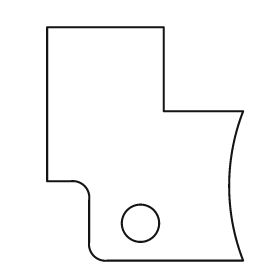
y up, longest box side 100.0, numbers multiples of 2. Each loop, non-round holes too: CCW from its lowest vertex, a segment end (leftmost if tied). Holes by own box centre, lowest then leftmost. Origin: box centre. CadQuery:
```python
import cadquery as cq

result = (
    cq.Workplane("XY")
    .moveTo(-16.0, -50.0)
    .lineTo(42.0, -50.0)
    .threePointArc((36.0, -18.0), (42.0, 14.0))
    .lineTo(8.0, 14.0)
    .lineTo(8.0, 50.0)
    .lineTo(-42.0, 50.0)
    .lineTo(-42.0, -16.0)
    .lineTo(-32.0, -16.0)
    .threePointArc((-26.0, -18.0), (-24.0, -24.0))
    .lineTo(-24.0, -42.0)
    .threePointArc((-22.0, -48.0), (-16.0, -50.0))
    .close()
    .moveTo(-2.0, -34.0)
    .circle(8.0)
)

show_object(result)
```